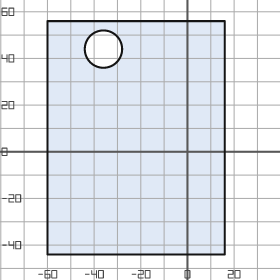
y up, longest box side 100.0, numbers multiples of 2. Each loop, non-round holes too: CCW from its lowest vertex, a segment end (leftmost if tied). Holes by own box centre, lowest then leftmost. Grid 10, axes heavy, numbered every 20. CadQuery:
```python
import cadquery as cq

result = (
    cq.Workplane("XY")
    .moveTo(-60.0, -44.0)
    .lineTo(16.0, -44.0)
    .lineTo(16.0, 56.0)
    .lineTo(-60.0, 56.0)
    .close()
    .moveTo(-36.0, 44.0)
    .circle(8.0)
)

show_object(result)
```